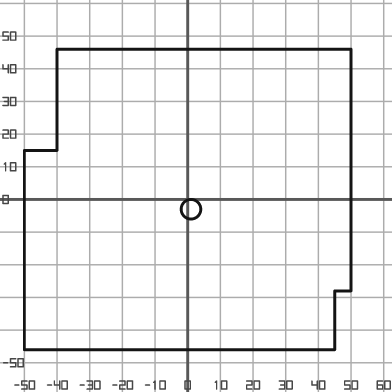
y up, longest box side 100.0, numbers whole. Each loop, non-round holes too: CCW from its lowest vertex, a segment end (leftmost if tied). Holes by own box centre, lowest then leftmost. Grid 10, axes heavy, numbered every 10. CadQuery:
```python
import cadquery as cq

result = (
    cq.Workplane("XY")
    .moveTo(-50.0, -46.0)
    .lineTo(45.0, -46.0)
    .lineTo(45.0, -28.0)
    .lineTo(50.0, -28.0)
    .lineTo(50.0, 46.0)
    .lineTo(-40.0, 46.0)
    .lineTo(-40.0, 15.0)
    .lineTo(-50.0, 15.0)
    .close()
    .moveTo(1.0, -3.0)
    .circle(3.0)
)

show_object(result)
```